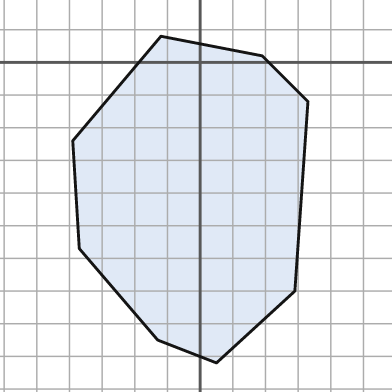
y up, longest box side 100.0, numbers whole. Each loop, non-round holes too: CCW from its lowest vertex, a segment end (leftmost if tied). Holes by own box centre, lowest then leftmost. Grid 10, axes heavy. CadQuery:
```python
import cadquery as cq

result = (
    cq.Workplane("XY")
    .moveTo(5.0, -92.0)
    .lineTo(29.0, -70.0)
    .lineTo(33.0, -12.0)
    .lineTo(19.0, 2.0)
    .lineTo(-12.0, 8.0)
    .lineTo(-39.0, -24.0)
    .lineTo(-37.0, -57.0)
    .lineTo(-13.0, -85.0)
    .close()
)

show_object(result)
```